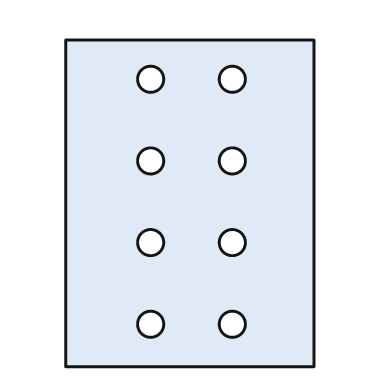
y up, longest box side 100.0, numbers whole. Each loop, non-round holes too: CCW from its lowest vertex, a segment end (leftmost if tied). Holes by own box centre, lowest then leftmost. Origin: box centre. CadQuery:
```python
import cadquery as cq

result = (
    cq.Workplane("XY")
    .moveTo(-38.0, -50.0)
    .lineTo(38.0, -50.0)
    .lineTo(38.0, 50.0)
    .lineTo(-38.0, 50.0)
    .close()
    .moveTo(-12.0, -37.0)
    .circle(4.0)
    .moveTo(13.0, -37.0)
    .circle(4.0)
    .moveTo(-12.0, -12.0)
    .circle(4.0)
    .moveTo(13.0, -12.0)
    .circle(4.0)
    .moveTo(-12.0, 13.0)
    .circle(4.0)
    .moveTo(13.0, 13.0)
    .circle(4.0)
    .moveTo(-12.0, 38.0)
    .circle(4.0)
    .moveTo(13.0, 38.0)
    .circle(4.0)
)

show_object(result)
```